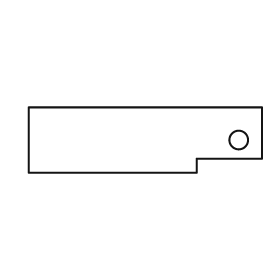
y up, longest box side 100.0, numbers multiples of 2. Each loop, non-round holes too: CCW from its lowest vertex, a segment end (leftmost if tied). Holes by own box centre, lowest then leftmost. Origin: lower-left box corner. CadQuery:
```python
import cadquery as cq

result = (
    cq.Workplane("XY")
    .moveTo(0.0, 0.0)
    .lineTo(72.0, 0.0)
    .lineTo(72.0, 6.0)
    .lineTo(100.0, 6.0)
    .lineTo(100.0, 28.0)
    .lineTo(0.0, 28.0)
    .close()
    .moveTo(90.0, 14.0)
    .circle(4.0)
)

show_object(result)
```